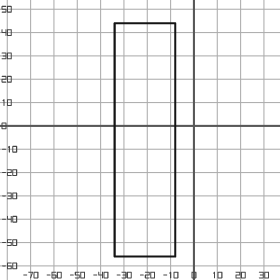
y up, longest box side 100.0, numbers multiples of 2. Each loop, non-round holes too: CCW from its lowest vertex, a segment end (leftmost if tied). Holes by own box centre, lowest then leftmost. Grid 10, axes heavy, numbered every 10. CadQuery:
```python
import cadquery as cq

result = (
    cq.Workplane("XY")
    .moveTo(-34.0, -56.0)
    .lineTo(-8.0, -56.0)
    .lineTo(-8.0, 44.0)
    .lineTo(-34.0, 44.0)
    .close()
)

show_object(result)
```